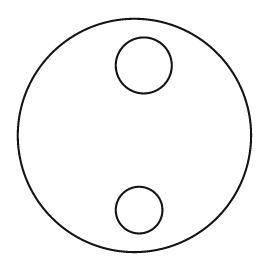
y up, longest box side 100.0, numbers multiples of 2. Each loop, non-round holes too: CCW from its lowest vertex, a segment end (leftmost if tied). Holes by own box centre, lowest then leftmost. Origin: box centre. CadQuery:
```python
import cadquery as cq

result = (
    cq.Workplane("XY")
    .moveTo(0.0, 0.0)
    .circle(50.0)
    .moveTo(2.0, -32.0)
    .circle(10.0)
    .moveTo(4.0, 30.0)
    .circle(12.0)
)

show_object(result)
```